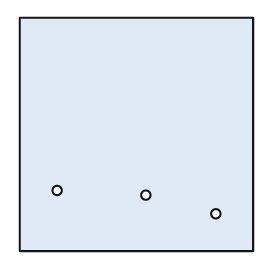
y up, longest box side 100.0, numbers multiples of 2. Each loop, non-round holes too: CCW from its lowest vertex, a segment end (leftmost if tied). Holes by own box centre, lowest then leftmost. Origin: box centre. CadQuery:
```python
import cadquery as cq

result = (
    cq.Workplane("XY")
    .moveTo(-50.0, -50.0)
    .lineTo(50.0, -50.0)
    .lineTo(50.0, 50.0)
    .lineTo(-50.0, 50.0)
    .close()
    .moveTo(34.0, -34.0)
    .circle(2.0)
    .moveTo(4.0, -26.0)
    .circle(2.0)
    .moveTo(-34.0, -24.0)
    .circle(2.0)
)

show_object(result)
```